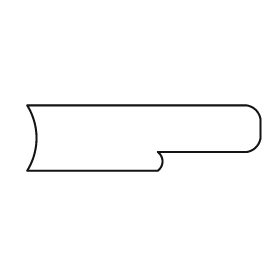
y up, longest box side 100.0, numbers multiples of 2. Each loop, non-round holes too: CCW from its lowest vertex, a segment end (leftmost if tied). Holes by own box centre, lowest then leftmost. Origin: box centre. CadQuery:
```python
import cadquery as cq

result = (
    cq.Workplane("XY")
    .moveTo(-50.0, -14.0)
    .lineTo(6.0, -14.0)
    .threePointArc((8.0, -10.0), (6.0, -6.0))
    .lineTo(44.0, -6.0)
    .threePointArc((48.0, -4.0), (50.0, 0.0))
    .lineTo(50.0, 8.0)
    .threePointArc((48.0, 12.0), (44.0, 14.0))
    .lineTo(-50.0, 14.0)
    .threePointArc((-46.0, 0.0), (-50.0, -14.0))
    .close()
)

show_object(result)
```